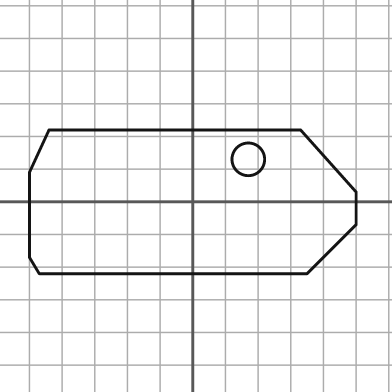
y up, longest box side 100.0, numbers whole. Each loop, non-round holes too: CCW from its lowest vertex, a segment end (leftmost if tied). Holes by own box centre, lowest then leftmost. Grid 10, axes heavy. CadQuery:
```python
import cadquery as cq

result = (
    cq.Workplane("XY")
    .moveTo(-47.0, -22.0)
    .lineTo(35.0, -22.0)
    .lineTo(50.0, -7.0)
    .lineTo(50.0, 3.0)
    .lineTo(33.0, 22.0)
    .lineTo(-44.0, 22.0)
    .lineTo(-50.0, 9.0)
    .lineTo(-50.0, -17.0)
    .close()
    .moveTo(17.0, 13.0)
    .circle(5.0)
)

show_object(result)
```